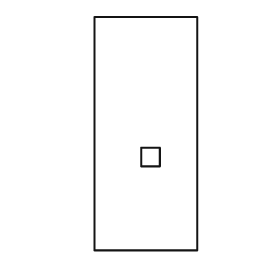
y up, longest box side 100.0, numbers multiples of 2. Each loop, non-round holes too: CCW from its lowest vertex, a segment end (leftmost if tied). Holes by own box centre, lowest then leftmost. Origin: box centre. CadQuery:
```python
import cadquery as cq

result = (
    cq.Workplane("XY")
    .moveTo(-22.0, -50.0)
    .lineTo(22.0, -50.0)
    .lineTo(22.0, 50.0)
    .lineTo(-22.0, 50.0)
    .close()
    .moveTo(-2.0, -14.0)
    .lineTo(6.0, -14.0)
    .lineTo(6.0, -6.0)
    .lineTo(-2.0, -6.0)
    .close()
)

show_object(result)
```